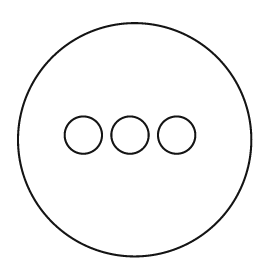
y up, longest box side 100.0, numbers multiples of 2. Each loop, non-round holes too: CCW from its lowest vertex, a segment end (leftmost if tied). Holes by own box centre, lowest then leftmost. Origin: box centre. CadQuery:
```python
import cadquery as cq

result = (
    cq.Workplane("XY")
    .moveTo(0.0, 0.0)
    .circle(50.0)
    .moveTo(-22.0, 2.0)
    .circle(8.0)
    .moveTo(-2.0, 2.0)
    .circle(8.0)
    .moveTo(18.0, 2.0)
    .circle(8.0)
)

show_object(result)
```